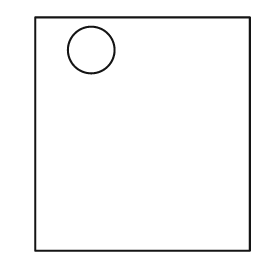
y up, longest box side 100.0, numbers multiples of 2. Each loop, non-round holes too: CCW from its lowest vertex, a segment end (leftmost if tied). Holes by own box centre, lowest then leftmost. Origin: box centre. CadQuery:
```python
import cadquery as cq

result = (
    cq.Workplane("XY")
    .moveTo(-46.0, -50.0)
    .lineTo(46.0, -50.0)
    .lineTo(46.0, 50.0)
    .lineTo(-46.0, 50.0)
    .close()
    .moveTo(-22.0, 36.0)
    .circle(10.0)
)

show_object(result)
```